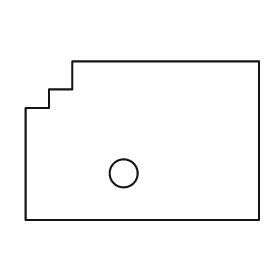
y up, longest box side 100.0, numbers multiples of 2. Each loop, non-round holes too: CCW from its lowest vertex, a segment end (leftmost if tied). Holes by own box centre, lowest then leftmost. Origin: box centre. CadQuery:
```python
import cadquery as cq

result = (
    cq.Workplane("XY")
    .moveTo(-50.0, -34.0)
    .lineTo(50.0, -34.0)
    .lineTo(50.0, 34.0)
    .lineTo(-30.0, 34.0)
    .lineTo(-30.0, 22.0)
    .lineTo(-40.0, 22.0)
    .lineTo(-40.0, 14.0)
    .lineTo(-50.0, 14.0)
    .close()
    .moveTo(-8.0, -14.0)
    .circle(6.0)
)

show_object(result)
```